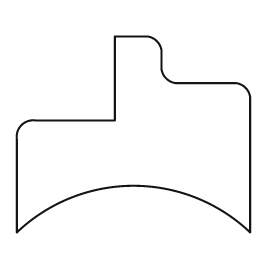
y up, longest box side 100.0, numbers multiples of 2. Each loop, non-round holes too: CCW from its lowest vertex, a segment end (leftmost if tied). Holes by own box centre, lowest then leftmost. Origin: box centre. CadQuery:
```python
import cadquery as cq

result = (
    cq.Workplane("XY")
    .moveTo(-50.0, -42.0)
    .threePointArc((0.0, -22.0), (50.0, -42.0))
    .lineTo(50.0, 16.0)
    .threePointArc((48.0, 20.0), (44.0, 22.0))
    .lineTo(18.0, 22.0)
    .threePointArc((14.0, 24.0), (12.0, 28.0))
    .lineTo(12.0, 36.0)
    .threePointArc((10.0, 40.0), (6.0, 42.0))
    .lineTo(-8.0, 42.0)
    .lineTo(-8.0, 6.0)
    .lineTo(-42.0, 6.0)
    .threePointArc((-48.0, 4.0), (-50.0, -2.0))
    .close()
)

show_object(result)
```